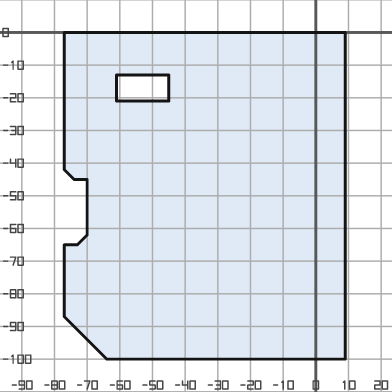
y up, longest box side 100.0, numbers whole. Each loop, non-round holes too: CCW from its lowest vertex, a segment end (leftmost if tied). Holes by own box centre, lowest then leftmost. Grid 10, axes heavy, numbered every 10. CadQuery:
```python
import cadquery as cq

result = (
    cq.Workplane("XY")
    .moveTo(-64.0, -100.0)
    .lineTo(9.0, -100.0)
    .lineTo(9.0, 0.0)
    .lineTo(-77.0, 0.0)
    .lineTo(-77.0, -42.0)
    .lineTo(-74.0, -45.0)
    .lineTo(-70.0, -45.0)
    .lineTo(-70.0, -62.0)
    .lineTo(-73.0, -65.0)
    .lineTo(-77.0, -65.0)
    .lineTo(-77.0, -87.0)
    .close()
    .moveTo(-61.0, -21.0)
    .lineTo(-45.0, -21.0)
    .lineTo(-45.0, -13.0)
    .lineTo(-61.0, -13.0)
    .close()
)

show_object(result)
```